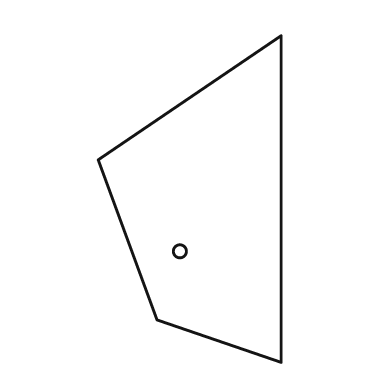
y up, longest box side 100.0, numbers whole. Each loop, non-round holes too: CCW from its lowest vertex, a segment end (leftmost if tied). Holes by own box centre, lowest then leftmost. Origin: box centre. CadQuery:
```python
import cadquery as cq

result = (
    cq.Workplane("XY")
    .moveTo(28.0, -50.0)
    .lineTo(28.0, 50.0)
    .lineTo(-28.0, 12.0)
    .lineTo(-10.0, -37.0)
    .close()
    .moveTo(-3.0, -16.0)
    .circle(2.0)
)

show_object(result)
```